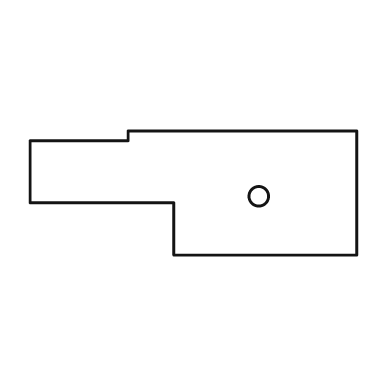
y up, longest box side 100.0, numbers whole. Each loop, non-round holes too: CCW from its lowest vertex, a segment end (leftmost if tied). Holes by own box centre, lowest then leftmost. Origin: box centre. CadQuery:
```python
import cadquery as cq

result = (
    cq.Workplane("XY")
    .moveTo(-6.0, -19.0)
    .lineTo(50.0, -19.0)
    .lineTo(50.0, 19.0)
    .lineTo(-20.0, 19.0)
    .lineTo(-20.0, 16.0)
    .lineTo(-50.0, 16.0)
    .lineTo(-50.0, -3.0)
    .lineTo(-6.0, -3.0)
    .close()
    .moveTo(20.0, -1.0)
    .circle(3.0)
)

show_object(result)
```